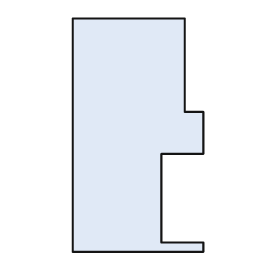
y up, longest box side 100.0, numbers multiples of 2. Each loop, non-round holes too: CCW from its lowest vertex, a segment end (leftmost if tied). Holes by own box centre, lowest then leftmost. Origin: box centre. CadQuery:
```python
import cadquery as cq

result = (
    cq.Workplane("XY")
    .moveTo(-28.0, -50.0)
    .lineTo(28.0, -50.0)
    .lineTo(28.0, -46.0)
    .lineTo(10.0, -46.0)
    .lineTo(10.0, -8.0)
    .lineTo(28.0, -8.0)
    .lineTo(28.0, 10.0)
    .lineTo(20.0, 10.0)
    .lineTo(20.0, 50.0)
    .lineTo(-28.0, 50.0)
    .close()
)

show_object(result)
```